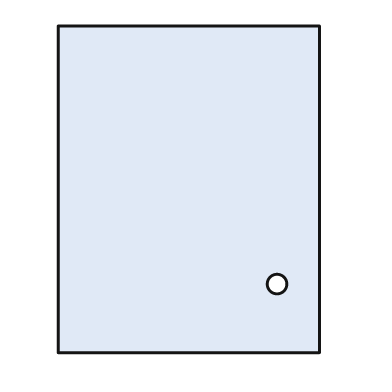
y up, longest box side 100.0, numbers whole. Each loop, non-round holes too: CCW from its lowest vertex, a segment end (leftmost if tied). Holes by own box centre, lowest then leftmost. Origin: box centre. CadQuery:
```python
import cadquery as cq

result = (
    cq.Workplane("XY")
    .moveTo(-40.0, -50.0)
    .lineTo(40.0, -50.0)
    .lineTo(40.0, 50.0)
    .lineTo(-40.0, 50.0)
    .close()
    .moveTo(27.0, -29.0)
    .circle(3.0)
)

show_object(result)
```